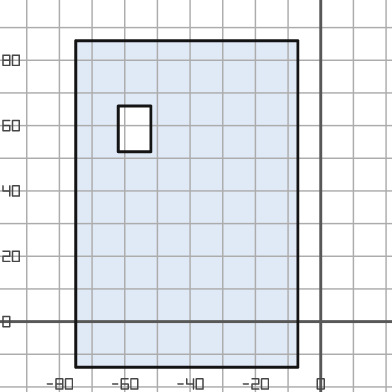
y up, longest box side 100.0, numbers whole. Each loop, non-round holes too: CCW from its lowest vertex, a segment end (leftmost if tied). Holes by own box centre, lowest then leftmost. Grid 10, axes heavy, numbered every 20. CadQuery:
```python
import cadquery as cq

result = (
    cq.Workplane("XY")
    .moveTo(-75.0, -14.0)
    .lineTo(-7.0, -14.0)
    .lineTo(-7.0, 86.0)
    .lineTo(-75.0, 86.0)
    .close()
    .moveTo(-62.0, 52.0)
    .lineTo(-52.0, 52.0)
    .lineTo(-52.0, 66.0)
    .lineTo(-62.0, 66.0)
    .close()
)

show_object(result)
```